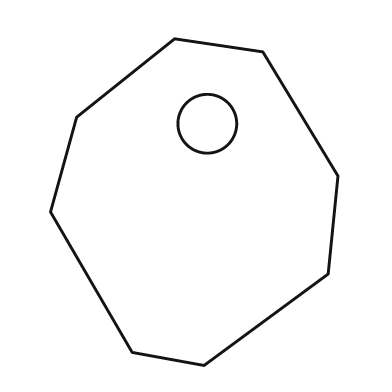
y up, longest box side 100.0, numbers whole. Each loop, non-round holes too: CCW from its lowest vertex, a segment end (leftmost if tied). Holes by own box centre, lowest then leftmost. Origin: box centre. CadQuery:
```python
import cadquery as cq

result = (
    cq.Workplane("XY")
    .moveTo(3.0, -50.0)
    .lineTo(41.0, -22.0)
    .lineTo(44.0, 8.0)
    .lineTo(21.0, 46.0)
    .lineTo(-6.0, 50.0)
    .lineTo(-36.0, 26.0)
    .lineTo(-44.0, -3.0)
    .lineTo(-19.0, -46.0)
    .close()
    .moveTo(4.0, 24.0)
    .circle(9.0)
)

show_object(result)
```